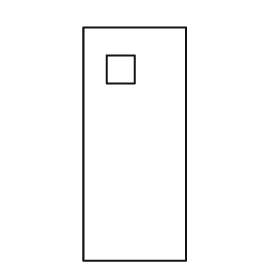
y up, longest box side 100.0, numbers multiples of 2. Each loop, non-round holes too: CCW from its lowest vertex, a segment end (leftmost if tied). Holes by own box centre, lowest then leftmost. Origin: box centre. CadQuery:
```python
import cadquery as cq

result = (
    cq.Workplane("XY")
    .moveTo(-22.0, -50.0)
    .lineTo(22.0, -50.0)
    .lineTo(22.0, 50.0)
    .lineTo(-22.0, 50.0)
    .close()
    .moveTo(-12.0, 26.0)
    .lineTo(0.0, 26.0)
    .lineTo(0.0, 38.0)
    .lineTo(-12.0, 38.0)
    .close()
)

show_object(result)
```